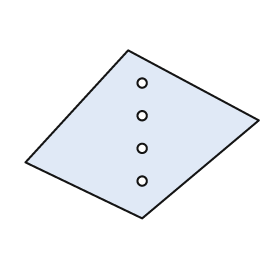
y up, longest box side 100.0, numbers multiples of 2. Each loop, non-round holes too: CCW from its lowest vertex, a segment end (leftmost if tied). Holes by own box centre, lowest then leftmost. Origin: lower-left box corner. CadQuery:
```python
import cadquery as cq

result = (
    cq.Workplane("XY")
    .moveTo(50.0, 0.0)
    .lineTo(100.0, 42.0)
    .lineTo(44.0, 72.0)
    .lineTo(0.0, 24.0)
    .close()
    .moveTo(50.0, 16.0)
    .circle(2.0)
    .moveTo(50.0, 30.0)
    .circle(2.0)
    .moveTo(50.0, 44.0)
    .circle(2.0)
    .moveTo(50.0, 58.0)
    .circle(2.0)
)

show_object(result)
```